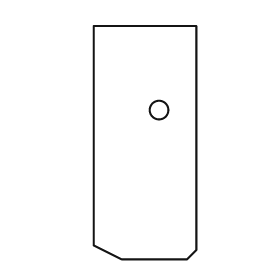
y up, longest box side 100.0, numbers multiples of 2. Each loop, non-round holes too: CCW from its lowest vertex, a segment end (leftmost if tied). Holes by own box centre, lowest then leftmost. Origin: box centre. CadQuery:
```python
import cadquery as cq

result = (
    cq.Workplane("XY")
    .moveTo(-10.0, -50.0)
    .lineTo(18.0, -50.0)
    .lineTo(22.0, -46.0)
    .lineTo(22.0, 50.0)
    .lineTo(-22.0, 50.0)
    .lineTo(-22.0, -44.0)
    .close()
    .moveTo(6.0, 14.0)
    .circle(4.0)
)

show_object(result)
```